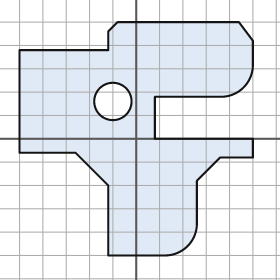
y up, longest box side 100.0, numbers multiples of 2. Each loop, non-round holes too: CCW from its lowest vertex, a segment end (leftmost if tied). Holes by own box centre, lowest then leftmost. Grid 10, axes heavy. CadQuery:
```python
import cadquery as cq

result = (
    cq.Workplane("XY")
    .moveTo(-12.0, -50.0)
    .lineTo(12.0, -50.0)
    .threePointArc((22.0, -46.0), (26.0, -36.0))
    .lineTo(26.0, -18.0)
    .lineTo(36.0, -8.0)
    .lineTo(50.0, -8.0)
    .lineTo(50.0, 0.0)
    .lineTo(8.0, 0.0)
    .lineTo(8.0, 18.0)
    .lineTo(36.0, 18.0)
    .threePointArc((46.0, 22.0), (50.0, 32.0))
    .lineTo(50.0, 42.0)
    .lineTo(44.0, 50.0)
    .lineTo(-8.0, 50.0)
    .lineTo(-12.0, 46.0)
    .lineTo(-12.0, 38.0)
    .lineTo(-50.0, 38.0)
    .lineTo(-50.0, -6.0)
    .lineTo(-26.0, -6.0)
    .lineTo(-12.0, -20.0)
    .close()
    .moveTo(-10.0, 16.0)
    .circle(8.0)
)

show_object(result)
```